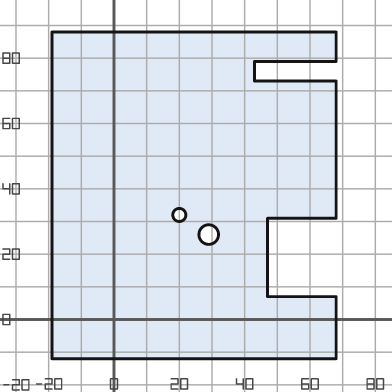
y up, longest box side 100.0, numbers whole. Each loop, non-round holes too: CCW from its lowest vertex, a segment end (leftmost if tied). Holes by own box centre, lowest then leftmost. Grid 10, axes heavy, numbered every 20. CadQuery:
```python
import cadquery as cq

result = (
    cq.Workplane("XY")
    .moveTo(-19.0, -12.0)
    .lineTo(68.0, -12.0)
    .lineTo(68.0, 7.0)
    .lineTo(47.0, 7.0)
    .lineTo(47.0, 31.0)
    .lineTo(68.0, 31.0)
    .lineTo(68.0, 73.0)
    .lineTo(43.0, 73.0)
    .lineTo(43.0, 79.0)
    .lineTo(68.0, 79.0)
    .lineTo(68.0, 88.0)
    .lineTo(-19.0, 88.0)
    .close()
    .moveTo(29.0, 26.0)
    .circle(3.0)
    .moveTo(20.0, 32.0)
    .circle(2.0)
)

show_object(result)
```